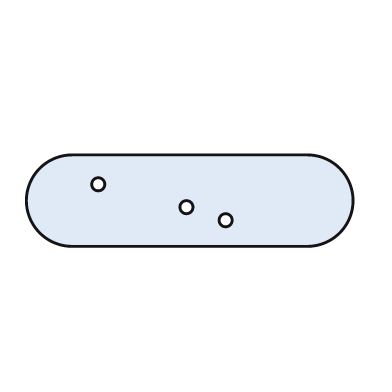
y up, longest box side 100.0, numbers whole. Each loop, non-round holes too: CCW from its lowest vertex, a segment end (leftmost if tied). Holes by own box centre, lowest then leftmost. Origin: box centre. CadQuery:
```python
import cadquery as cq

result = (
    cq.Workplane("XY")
    .moveTo(-36.0, -14.0)
    .lineTo(36.0, -14.0)
    .threePointArc((50.0, 0.0), (36.0, 14.0))
    .lineTo(-36.0, 14.0)
    .threePointArc((-50.0, 0.0), (-36.0, -14.0))
    .close()
    .moveTo(11.0, -6.0)
    .circle(2.0)
    .moveTo(-1.0, -2.0)
    .circle(2.0)
    .moveTo(-28.0, 5.0)
    .circle(2.0)
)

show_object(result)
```